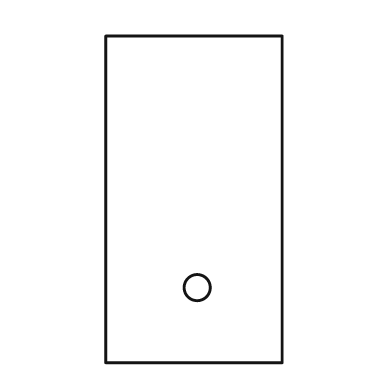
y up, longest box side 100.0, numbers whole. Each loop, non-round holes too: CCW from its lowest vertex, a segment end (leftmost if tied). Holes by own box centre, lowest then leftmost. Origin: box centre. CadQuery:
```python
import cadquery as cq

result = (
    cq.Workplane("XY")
    .moveTo(-27.0, -50.0)
    .lineTo(27.0, -50.0)
    .lineTo(27.0, 50.0)
    .lineTo(-27.0, 50.0)
    .close()
    .moveTo(1.0, -27.0)
    .circle(4.0)
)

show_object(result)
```